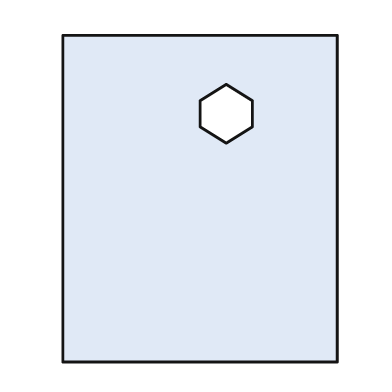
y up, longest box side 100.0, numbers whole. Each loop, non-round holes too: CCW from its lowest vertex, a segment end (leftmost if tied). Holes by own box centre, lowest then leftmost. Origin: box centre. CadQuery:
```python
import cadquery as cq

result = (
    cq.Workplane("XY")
    .moveTo(-42.0, -50.0)
    .lineTo(42.0, -50.0)
    .lineTo(42.0, 50.0)
    .lineTo(-42.0, 50.0)
    .close()
    .moveTo(8.0, 17.0)
    .lineTo(16.0, 22.0)
    .lineTo(16.0, 30.0)
    .lineTo(8.0, 35.0)
    .lineTo(0.0, 30.0)
    .lineTo(0.0, 22.0)
    .close()
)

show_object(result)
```